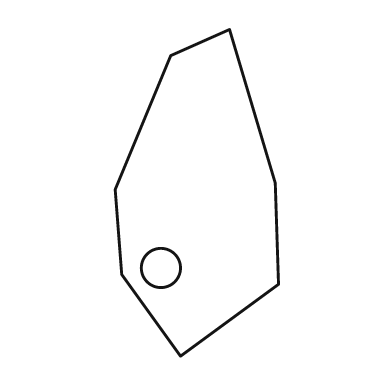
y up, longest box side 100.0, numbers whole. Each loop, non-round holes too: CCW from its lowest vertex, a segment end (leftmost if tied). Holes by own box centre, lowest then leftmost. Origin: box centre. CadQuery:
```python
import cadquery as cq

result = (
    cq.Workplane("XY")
    .moveTo(-5.0, -50.0)
    .lineTo(25.0, -28.0)
    .lineTo(24.0, 3.0)
    .lineTo(10.0, 50.0)
    .lineTo(-8.0, 42.0)
    .lineTo(-25.0, 1.0)
    .lineTo(-23.0, -25.0)
    .close()
    .moveTo(-11.0, -23.0)
    .circle(6.0)
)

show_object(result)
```